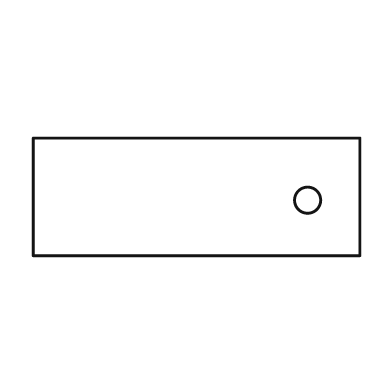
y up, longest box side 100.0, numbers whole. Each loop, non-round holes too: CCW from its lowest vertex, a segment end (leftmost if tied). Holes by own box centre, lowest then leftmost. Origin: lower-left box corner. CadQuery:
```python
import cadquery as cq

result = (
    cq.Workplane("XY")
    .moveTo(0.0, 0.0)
    .lineTo(100.0, 0.0)
    .lineTo(100.0, 36.0)
    .lineTo(0.0, 36.0)
    .close()
    .moveTo(84.0, 17.0)
    .circle(4.0)
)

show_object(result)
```